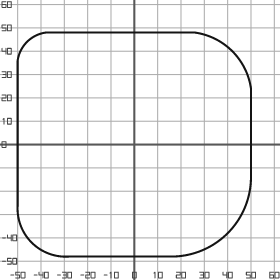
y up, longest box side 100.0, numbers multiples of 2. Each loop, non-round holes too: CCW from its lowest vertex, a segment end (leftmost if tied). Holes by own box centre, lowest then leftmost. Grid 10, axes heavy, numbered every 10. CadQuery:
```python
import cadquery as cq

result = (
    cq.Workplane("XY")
    .moveTo(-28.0, -48.0)
    .lineTo(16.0, -48.0)
    .threePointArc((40.0, -38.0), (50.0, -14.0))
    .lineTo(50.0, 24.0)
    .threePointArc((42.0, 40.0), (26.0, 48.0))
    .lineTo(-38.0, 48.0)
    .threePointArc((-46.0, 44.0), (-50.0, 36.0))
    .lineTo(-50.0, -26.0)
    .threePointArc((-44.0, -42.0), (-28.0, -48.0))
    .close()
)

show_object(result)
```